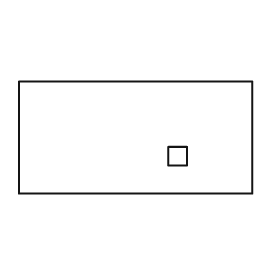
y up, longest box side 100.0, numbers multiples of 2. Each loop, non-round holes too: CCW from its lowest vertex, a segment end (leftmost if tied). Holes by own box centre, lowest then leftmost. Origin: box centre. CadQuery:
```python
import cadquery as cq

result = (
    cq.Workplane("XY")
    .moveTo(-50.0, -24.0)
    .lineTo(50.0, -24.0)
    .lineTo(50.0, 24.0)
    .lineTo(-50.0, 24.0)
    .close()
    .moveTo(14.0, -12.0)
    .lineTo(22.0, -12.0)
    .lineTo(22.0, -4.0)
    .lineTo(14.0, -4.0)
    .close()
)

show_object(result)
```